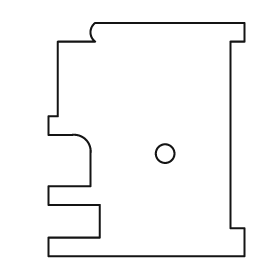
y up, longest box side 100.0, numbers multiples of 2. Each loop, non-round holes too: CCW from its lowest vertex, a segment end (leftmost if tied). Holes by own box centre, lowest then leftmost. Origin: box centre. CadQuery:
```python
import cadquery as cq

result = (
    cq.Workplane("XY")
    .moveTo(-42.0, -50.0)
    .lineTo(42.0, -50.0)
    .lineTo(42.0, -38.0)
    .lineTo(36.0, -38.0)
    .lineTo(36.0, 42.0)
    .lineTo(42.0, 42.0)
    .lineTo(42.0, 50.0)
    .lineTo(-22.0, 50.0)
    .threePointArc((-24.0, 46.0), (-22.0, 42.0))
    .lineTo(-38.0, 42.0)
    .lineTo(-38.0, 10.0)
    .lineTo(-42.0, 10.0)
    .lineTo(-42.0, 2.0)
    .lineTo(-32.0, 2.0)
    .threePointArc((-26.0, 0.0), (-24.0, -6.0))
    .lineTo(-24.0, -20.0)
    .lineTo(-42.0, -20.0)
    .lineTo(-42.0, -28.0)
    .lineTo(-20.0, -28.0)
    .lineTo(-20.0, -42.0)
    .lineTo(-42.0, -42.0)
    .close()
    .moveTo(8.0, -6.0)
    .circle(4.0)
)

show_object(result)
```